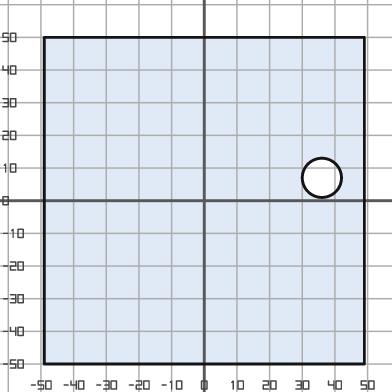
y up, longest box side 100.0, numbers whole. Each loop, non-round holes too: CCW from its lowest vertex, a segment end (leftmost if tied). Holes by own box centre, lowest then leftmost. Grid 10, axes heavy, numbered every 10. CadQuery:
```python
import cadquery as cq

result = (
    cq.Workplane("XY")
    .moveTo(-49.0, -50.0)
    .lineTo(49.0, -50.0)
    .lineTo(49.0, 50.0)
    .lineTo(-49.0, 50.0)
    .close()
    .moveTo(36.0, 7.0)
    .circle(6.0)
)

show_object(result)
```